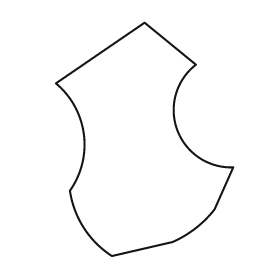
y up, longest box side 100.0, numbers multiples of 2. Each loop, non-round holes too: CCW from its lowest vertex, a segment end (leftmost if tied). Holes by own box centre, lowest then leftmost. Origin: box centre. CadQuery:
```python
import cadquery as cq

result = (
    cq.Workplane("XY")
    .moveTo(-14.0, -50.0)
    .lineTo(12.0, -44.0)
    .threePointArc((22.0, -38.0), (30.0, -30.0))
    .lineTo(38.0, -12.0)
    .threePointArc((14.0, 4.0), (22.0, 32.0))
    .lineTo(0.0, 50.0)
    .lineTo(-38.0, 24.0)
    .threePointArc((-26.0, 2.0), (-32.0, -22.0))
    .threePointArc((-26.0, -38.0), (-14.0, -50.0))
    .close()
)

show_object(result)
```